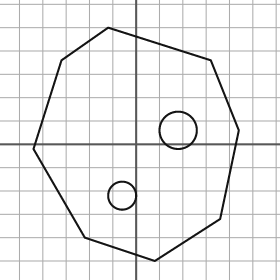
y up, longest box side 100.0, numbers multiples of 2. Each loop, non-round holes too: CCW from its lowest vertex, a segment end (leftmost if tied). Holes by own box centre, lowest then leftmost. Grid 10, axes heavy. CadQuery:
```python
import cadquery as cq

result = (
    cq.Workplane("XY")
    .moveTo(8.0, -50.0)
    .lineTo(36.0, -32.0)
    .lineTo(44.0, 6.0)
    .lineTo(32.0, 36.0)
    .lineTo(-12.0, 50.0)
    .lineTo(-32.0, 36.0)
    .lineTo(-44.0, -2.0)
    .lineTo(-22.0, -40.0)
    .close()
    .moveTo(-6.0, -22.0)
    .circle(6.0)
    .moveTo(18.0, 6.0)
    .circle(8.0)
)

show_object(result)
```